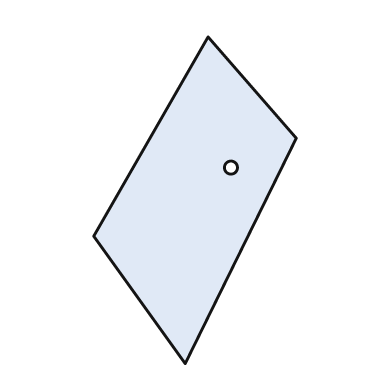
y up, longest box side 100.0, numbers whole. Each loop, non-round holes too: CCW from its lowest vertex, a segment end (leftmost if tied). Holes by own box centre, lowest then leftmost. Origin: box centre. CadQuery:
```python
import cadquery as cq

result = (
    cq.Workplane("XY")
    .moveTo(-3.0, -50.0)
    .lineTo(31.0, 19.0)
    .lineTo(4.0, 50.0)
    .lineTo(-31.0, -11.0)
    .close()
    .moveTo(11.0, 10.0)
    .circle(2.0)
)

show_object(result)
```